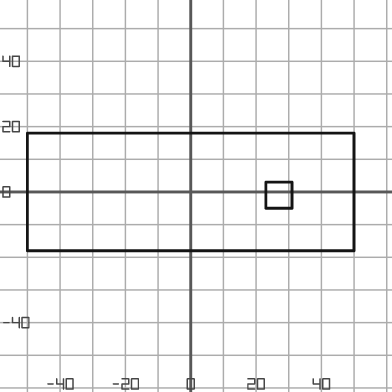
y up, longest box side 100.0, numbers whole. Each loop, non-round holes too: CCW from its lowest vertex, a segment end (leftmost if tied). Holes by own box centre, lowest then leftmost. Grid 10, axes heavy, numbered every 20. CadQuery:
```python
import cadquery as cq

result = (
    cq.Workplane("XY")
    .moveTo(-50.0, -18.0)
    .lineTo(50.0, -18.0)
    .lineTo(50.0, 18.0)
    .lineTo(-50.0, 18.0)
    .close()
    .moveTo(23.0, -5.0)
    .lineTo(31.0, -5.0)
    .lineTo(31.0, 3.0)
    .lineTo(23.0, 3.0)
    .close()
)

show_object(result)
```